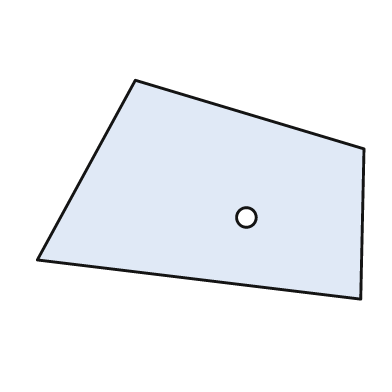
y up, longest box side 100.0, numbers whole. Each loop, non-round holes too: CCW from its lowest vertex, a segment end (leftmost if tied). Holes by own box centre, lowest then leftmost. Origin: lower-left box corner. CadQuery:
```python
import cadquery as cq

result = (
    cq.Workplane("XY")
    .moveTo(99.0, 0.0)
    .lineTo(100.0, 46.0)
    .lineTo(30.0, 67.0)
    .lineTo(0.0, 12.0)
    .close()
    .moveTo(64.0, 25.0)
    .circle(3.0)
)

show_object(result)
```